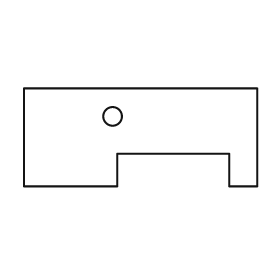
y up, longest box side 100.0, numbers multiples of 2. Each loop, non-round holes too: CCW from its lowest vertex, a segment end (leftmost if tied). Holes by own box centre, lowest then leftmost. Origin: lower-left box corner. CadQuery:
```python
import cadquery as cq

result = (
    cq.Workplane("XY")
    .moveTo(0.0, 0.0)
    .lineTo(40.0, 0.0)
    .lineTo(40.0, 14.0)
    .lineTo(88.0, 14.0)
    .lineTo(88.0, 0.0)
    .lineTo(100.0, 0.0)
    .lineTo(100.0, 42.0)
    .lineTo(0.0, 42.0)
    .close()
    .moveTo(38.0, 30.0)
    .circle(4.0)
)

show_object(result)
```